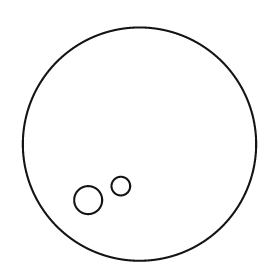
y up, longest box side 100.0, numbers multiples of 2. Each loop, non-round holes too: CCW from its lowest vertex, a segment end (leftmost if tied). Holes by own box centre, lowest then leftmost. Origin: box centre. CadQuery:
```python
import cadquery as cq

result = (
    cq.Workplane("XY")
    .moveTo(0.0, 0.0)
    .circle(50.0)
    .moveTo(-22.0, -24.0)
    .circle(6.0)
    .moveTo(-8.0, -18.0)
    .circle(4.0)
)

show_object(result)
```